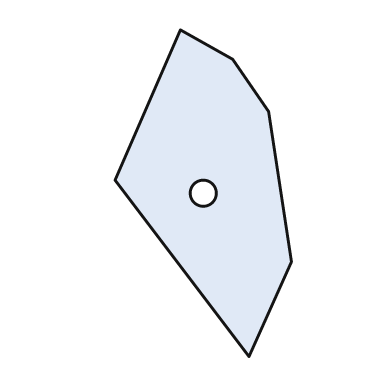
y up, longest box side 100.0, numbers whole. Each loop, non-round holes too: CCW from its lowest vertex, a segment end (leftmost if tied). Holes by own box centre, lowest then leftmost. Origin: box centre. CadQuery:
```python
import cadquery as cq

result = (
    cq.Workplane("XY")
    .moveTo(14.0, -50.0)
    .lineTo(27.0, -21.0)
    .lineTo(20.0, 25.0)
    .lineTo(9.0, 41.0)
    .lineTo(-7.0, 50.0)
    .lineTo(-27.0, 4.0)
    .close()
    .moveTo(0.0, 0.0)
    .circle(4.0)
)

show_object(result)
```